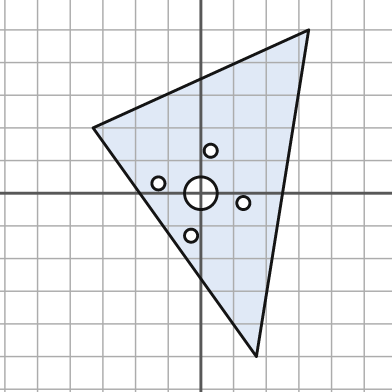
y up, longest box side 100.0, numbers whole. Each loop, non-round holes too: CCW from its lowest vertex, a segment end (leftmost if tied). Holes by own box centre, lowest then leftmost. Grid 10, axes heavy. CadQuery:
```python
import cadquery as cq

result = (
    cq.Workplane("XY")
    .moveTo(17.0, -50.0)
    .lineTo(33.0, 50.0)
    .lineTo(-33.0, 20.0)
    .close()
    .moveTo(-3.0, -13.0)
    .circle(2.0)
    .moveTo(13.0, -3.0)
    .circle(2.0)
    .moveTo(0.0, 0.0)
    .circle(5.0)
    .moveTo(-13.0, 3.0)
    .circle(2.0)
    .moveTo(3.0, 13.0)
    .circle(2.0)
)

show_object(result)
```